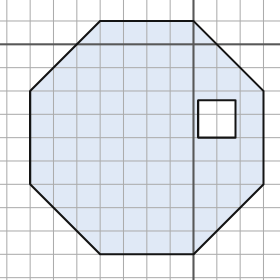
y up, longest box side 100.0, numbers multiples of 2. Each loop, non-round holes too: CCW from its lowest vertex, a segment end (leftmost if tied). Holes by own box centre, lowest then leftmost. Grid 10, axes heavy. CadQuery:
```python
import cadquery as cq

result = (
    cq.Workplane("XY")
    .moveTo(-40.0, -90.0)
    .lineTo(0.0, -90.0)
    .lineTo(30.0, -60.0)
    .lineTo(30.0, -20.0)
    .lineTo(0.0, 10.0)
    .lineTo(-40.0, 10.0)
    .lineTo(-70.0, -20.0)
    .lineTo(-70.0, -60.0)
    .close()
    .moveTo(2.0, -40.0)
    .lineTo(18.0, -40.0)
    .lineTo(18.0, -24.0)
    .lineTo(2.0, -24.0)
    .close()
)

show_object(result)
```